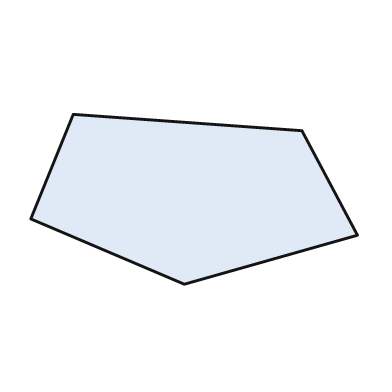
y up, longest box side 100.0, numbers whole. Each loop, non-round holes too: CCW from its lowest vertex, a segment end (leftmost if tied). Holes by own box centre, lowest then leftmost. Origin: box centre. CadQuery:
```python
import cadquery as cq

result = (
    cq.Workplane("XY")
    .moveTo(-3.0, -26.0)
    .lineTo(50.0, -11.0)
    .lineTo(33.0, 21.0)
    .lineTo(-37.0, 26.0)
    .lineTo(-50.0, -6.0)
    .close()
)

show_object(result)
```